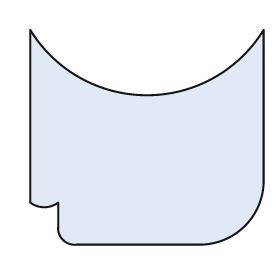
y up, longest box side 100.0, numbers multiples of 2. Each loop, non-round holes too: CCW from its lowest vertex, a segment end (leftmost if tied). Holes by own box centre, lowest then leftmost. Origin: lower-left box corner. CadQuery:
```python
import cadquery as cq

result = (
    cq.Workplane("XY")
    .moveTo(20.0, 0.0)
    .lineTo(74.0, 0.0)
    .threePointArc((92.0, 8.0), (100.0, 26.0))
    .lineTo(100.0, 92.0)
    .threePointArc((50.0, 64.0), (0.0, 92.0))
    .lineTo(0.0, 18.0)
    .threePointArc((6.0, 16.0), (12.0, 18.0))
    .lineTo(12.0, 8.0)
    .threePointArc((14.0, 2.0), (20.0, 0.0))
    .close()
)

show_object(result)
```